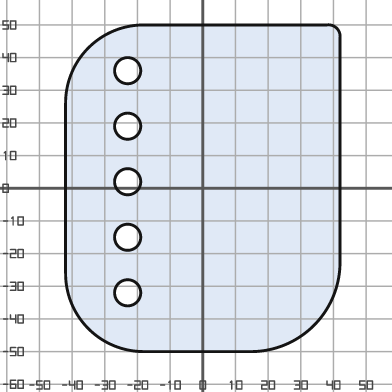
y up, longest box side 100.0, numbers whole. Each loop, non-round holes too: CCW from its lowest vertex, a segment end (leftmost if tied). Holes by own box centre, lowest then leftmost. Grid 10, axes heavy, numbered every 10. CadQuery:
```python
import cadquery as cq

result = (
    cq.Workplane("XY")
    .moveTo(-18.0, -50.0)
    .lineTo(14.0, -50.0)
    .threePointArc((34.0, -42.0), (42.0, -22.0))
    .lineTo(42.0, 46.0)
    .threePointArc((41.0, 49.0), (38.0, 50.0))
    .lineTo(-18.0, 50.0)
    .threePointArc((-35.0, 43.0), (-42.0, 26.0))
    .lineTo(-42.0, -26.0)
    .threePointArc((-35.0, -43.0), (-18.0, -50.0))
    .close()
    .moveTo(-23.0, -32.0)
    .circle(4.0)
    .moveTo(-23.0, -15.0)
    .circle(4.0)
    .moveTo(-23.0, 2.0)
    .circle(4.0)
    .moveTo(-23.0, 19.0)
    .circle(4.0)
    .moveTo(-23.0, 36.0)
    .circle(4.0)
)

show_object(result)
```